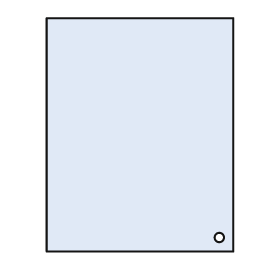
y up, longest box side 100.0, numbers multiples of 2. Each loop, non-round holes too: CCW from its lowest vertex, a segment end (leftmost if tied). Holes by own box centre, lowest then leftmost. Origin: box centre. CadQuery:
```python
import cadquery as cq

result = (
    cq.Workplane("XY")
    .moveTo(-40.0, -50.0)
    .lineTo(40.0, -50.0)
    .lineTo(40.0, 50.0)
    .lineTo(-40.0, 50.0)
    .close()
    .moveTo(34.0, -44.0)
    .circle(2.0)
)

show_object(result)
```